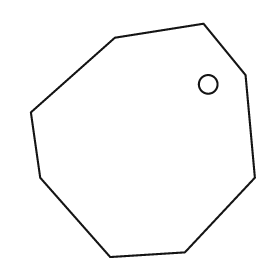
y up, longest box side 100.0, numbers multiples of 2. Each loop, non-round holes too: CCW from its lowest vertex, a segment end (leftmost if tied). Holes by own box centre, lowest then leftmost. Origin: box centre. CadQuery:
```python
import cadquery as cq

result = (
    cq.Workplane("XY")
    .moveTo(-14.0, -50.0)
    .lineTo(18.0, -48.0)
    .lineTo(48.0, -16.0)
    .lineTo(44.0, 28.0)
    .lineTo(26.0, 50.0)
    .lineTo(-12.0, 44.0)
    .lineTo(-48.0, 12.0)
    .lineTo(-44.0, -16.0)
    .close()
    .moveTo(28.0, 24.0)
    .circle(4.0)
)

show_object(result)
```